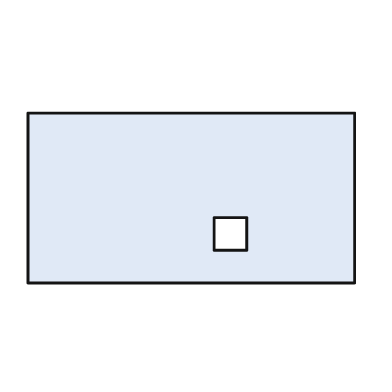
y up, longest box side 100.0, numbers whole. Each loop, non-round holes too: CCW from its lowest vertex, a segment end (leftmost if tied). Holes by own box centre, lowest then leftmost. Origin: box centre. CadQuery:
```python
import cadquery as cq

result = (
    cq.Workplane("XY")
    .moveTo(-50.0, -26.0)
    .lineTo(50.0, -26.0)
    .lineTo(50.0, 26.0)
    .lineTo(-50.0, 26.0)
    .close()
    .moveTo(7.0, -16.0)
    .lineTo(17.0, -16.0)
    .lineTo(17.0, -6.0)
    .lineTo(7.0, -6.0)
    .close()
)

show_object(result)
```